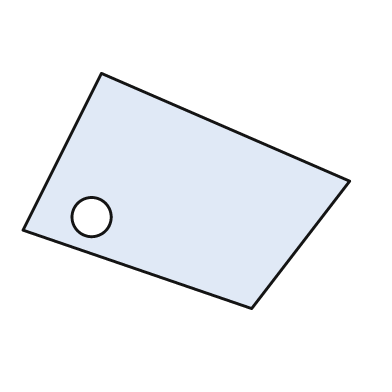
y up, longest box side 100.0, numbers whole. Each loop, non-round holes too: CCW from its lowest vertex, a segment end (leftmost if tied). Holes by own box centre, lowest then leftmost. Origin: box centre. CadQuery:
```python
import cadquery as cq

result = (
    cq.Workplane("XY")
    .moveTo(20.0, -36.0)
    .lineTo(50.0, 3.0)
    .lineTo(-26.0, 36.0)
    .lineTo(-50.0, -12.0)
    .close()
    .moveTo(-29.0, -8.0)
    .circle(6.0)
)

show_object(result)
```